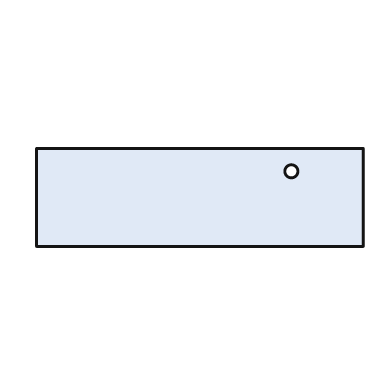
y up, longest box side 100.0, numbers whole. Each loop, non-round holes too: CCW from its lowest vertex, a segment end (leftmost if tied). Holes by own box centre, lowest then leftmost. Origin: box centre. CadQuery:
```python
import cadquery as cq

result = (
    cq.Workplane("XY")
    .moveTo(-50.0, -15.0)
    .lineTo(50.0, -15.0)
    .lineTo(50.0, 15.0)
    .lineTo(-50.0, 15.0)
    .close()
    .moveTo(28.0, 8.0)
    .circle(2.0)
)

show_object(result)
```